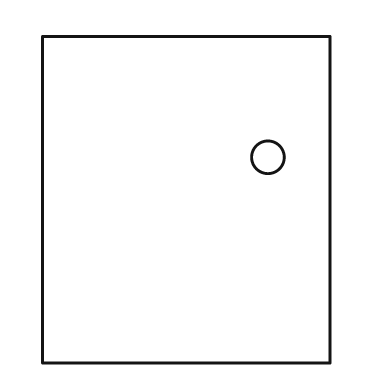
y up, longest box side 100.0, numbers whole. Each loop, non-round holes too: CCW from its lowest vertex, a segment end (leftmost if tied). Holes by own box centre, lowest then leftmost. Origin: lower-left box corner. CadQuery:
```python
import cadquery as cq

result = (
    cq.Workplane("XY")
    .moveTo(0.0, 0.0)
    .lineTo(88.0, 0.0)
    .lineTo(88.0, 100.0)
    .lineTo(0.0, 100.0)
    .close()
    .moveTo(69.0, 63.0)
    .circle(5.0)
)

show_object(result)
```